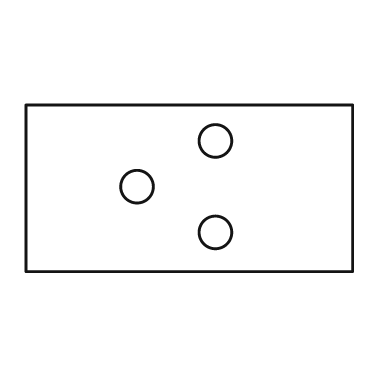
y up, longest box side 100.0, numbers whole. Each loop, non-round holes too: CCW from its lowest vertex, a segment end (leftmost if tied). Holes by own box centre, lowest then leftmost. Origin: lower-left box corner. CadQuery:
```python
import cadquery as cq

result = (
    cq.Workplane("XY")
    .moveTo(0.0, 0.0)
    .lineTo(100.0, 0.0)
    .lineTo(100.0, 51.0)
    .lineTo(0.0, 51.0)
    .close()
    .moveTo(58.0, 12.0)
    .circle(5.0)
    .moveTo(34.0, 26.0)
    .circle(5.0)
    .moveTo(58.0, 40.0)
    .circle(5.0)
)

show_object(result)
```